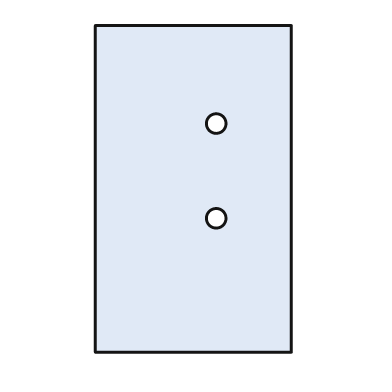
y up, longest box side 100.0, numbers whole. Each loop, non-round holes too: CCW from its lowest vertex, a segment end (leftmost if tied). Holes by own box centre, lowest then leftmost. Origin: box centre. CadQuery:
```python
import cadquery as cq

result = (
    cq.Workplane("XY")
    .moveTo(-30.0, -50.0)
    .lineTo(30.0, -50.0)
    .lineTo(30.0, 50.0)
    .lineTo(-30.0, 50.0)
    .close()
    .moveTo(7.0, -9.0)
    .circle(3.0)
    .moveTo(7.0, 20.0)
    .circle(3.0)
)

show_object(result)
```